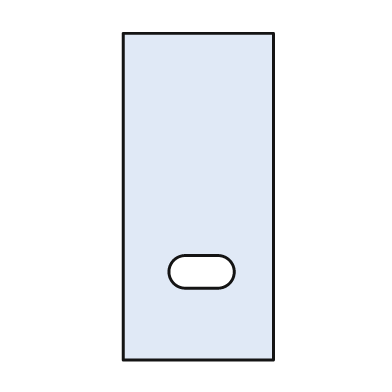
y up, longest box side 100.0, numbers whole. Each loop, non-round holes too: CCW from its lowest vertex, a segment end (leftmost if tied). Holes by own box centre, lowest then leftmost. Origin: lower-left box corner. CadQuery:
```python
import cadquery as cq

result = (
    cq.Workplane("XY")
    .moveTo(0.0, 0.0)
    .lineTo(46.0, 0.0)
    .lineTo(46.0, 100.0)
    .lineTo(0.0, 100.0)
    .close()
    .moveTo(19.0, 22.0)
    .lineTo(29.0, 22.0)
    .threePointArc((34.0, 27.0), (29.0, 32.0))
    .lineTo(19.0, 32.0)
    .threePointArc((14.0, 27.0), (19.0, 22.0))
    .close()
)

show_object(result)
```